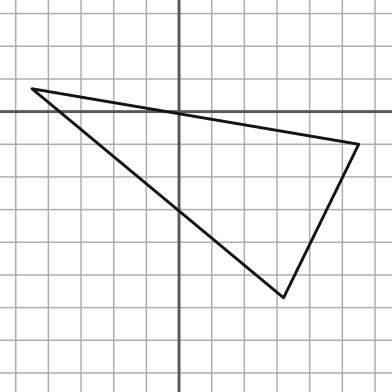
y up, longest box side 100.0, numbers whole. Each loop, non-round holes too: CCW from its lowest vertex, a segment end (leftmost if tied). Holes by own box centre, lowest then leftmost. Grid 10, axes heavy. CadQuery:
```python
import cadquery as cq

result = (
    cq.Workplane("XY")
    .moveTo(32.0, -57.0)
    .lineTo(55.0, -10.0)
    .lineTo(-45.0, 7.0)
    .close()
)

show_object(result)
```